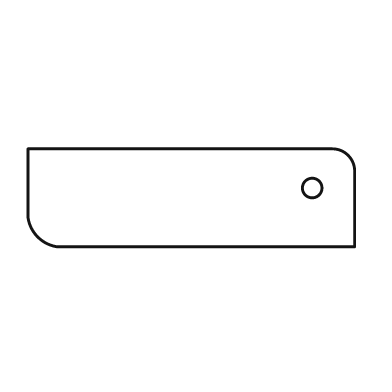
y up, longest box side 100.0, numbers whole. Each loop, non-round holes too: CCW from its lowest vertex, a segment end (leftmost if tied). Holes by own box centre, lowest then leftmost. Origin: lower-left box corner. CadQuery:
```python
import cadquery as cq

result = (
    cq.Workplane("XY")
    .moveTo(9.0, 0.0)
    .lineTo(100.0, 0.0)
    .lineTo(100.0, 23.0)
    .threePointArc((98.0, 28.0), (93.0, 30.0))
    .lineTo(0.0, 30.0)
    .lineTo(0.0, 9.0)
    .threePointArc((3.0, 3.0), (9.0, 0.0))
    .close()
    .moveTo(87.0, 18.0)
    .circle(3.0)
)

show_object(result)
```